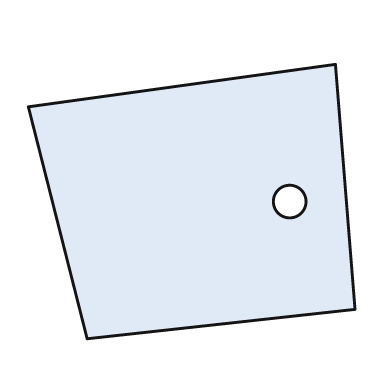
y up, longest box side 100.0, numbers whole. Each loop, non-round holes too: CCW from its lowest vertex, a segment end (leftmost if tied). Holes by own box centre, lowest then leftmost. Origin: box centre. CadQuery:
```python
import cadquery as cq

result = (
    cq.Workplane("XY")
    .moveTo(-32.0, -42.0)
    .lineTo(50.0, -33.0)
    .lineTo(44.0, 42.0)
    .lineTo(-50.0, 29.0)
    .close()
    .moveTo(30.0, 0.0)
    .circle(5.0)
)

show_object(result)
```